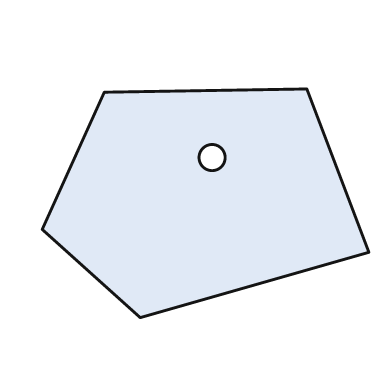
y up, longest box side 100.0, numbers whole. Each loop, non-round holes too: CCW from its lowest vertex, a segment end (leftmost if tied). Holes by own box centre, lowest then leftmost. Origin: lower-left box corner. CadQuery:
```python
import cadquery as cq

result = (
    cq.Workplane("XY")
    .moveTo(30.0, 0.0)
    .lineTo(100.0, 20.0)
    .lineTo(81.0, 70.0)
    .lineTo(19.0, 69.0)
    .lineTo(0.0, 27.0)
    .close()
    .moveTo(52.0, 49.0)
    .circle(4.0)
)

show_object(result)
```